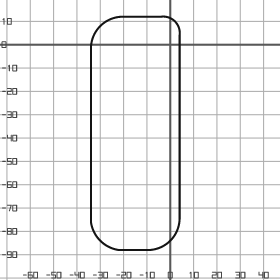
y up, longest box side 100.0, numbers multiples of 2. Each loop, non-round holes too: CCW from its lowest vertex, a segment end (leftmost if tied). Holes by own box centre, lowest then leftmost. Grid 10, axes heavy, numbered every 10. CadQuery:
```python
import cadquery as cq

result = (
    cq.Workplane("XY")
    .moveTo(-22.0, -88.0)
    .lineTo(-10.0, -88.0)
    .threePointArc((0.0, -84.0), (4.0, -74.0))
    .lineTo(4.0, 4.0)
    .threePointArc((2.0, 10.0), (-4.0, 12.0))
    .lineTo(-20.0, 12.0)
    .threePointArc((-30.0, 8.0), (-34.0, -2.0))
    .lineTo(-34.0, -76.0)
    .threePointArc((-30.0, -84.0), (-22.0, -88.0))
    .close()
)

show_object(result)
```